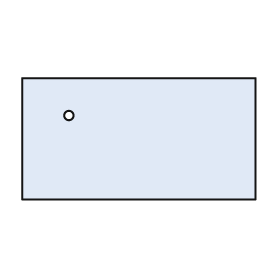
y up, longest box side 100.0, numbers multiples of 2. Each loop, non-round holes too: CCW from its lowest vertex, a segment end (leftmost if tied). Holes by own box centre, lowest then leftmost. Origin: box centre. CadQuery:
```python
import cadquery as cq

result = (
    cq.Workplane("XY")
    .moveTo(-50.0, -26.0)
    .lineTo(50.0, -26.0)
    .lineTo(50.0, 26.0)
    .lineTo(-50.0, 26.0)
    .close()
    .moveTo(-30.0, 10.0)
    .circle(2.0)
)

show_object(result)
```